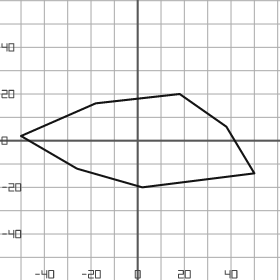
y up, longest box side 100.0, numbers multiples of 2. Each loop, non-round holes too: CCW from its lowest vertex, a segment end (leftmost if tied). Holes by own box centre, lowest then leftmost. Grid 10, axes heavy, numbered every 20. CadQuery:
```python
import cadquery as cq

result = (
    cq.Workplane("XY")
    .moveTo(2.0, -20.0)
    .lineTo(50.0, -14.0)
    .lineTo(38.0, 6.0)
    .lineTo(18.0, 20.0)
    .lineTo(-18.0, 16.0)
    .lineTo(-50.0, 2.0)
    .lineTo(-26.0, -12.0)
    .close()
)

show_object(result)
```